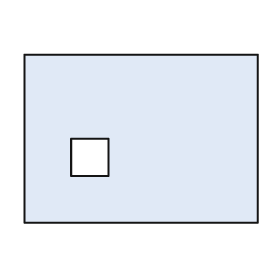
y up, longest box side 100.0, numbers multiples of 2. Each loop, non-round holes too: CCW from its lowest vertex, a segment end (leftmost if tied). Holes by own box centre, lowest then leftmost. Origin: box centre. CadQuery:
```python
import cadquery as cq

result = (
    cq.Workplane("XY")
    .moveTo(-50.0, -36.0)
    .lineTo(50.0, -36.0)
    .lineTo(50.0, 36.0)
    .lineTo(-50.0, 36.0)
    .close()
    .moveTo(-30.0, -16.0)
    .lineTo(-14.0, -16.0)
    .lineTo(-14.0, 0.0)
    .lineTo(-30.0, 0.0)
    .close()
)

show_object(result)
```